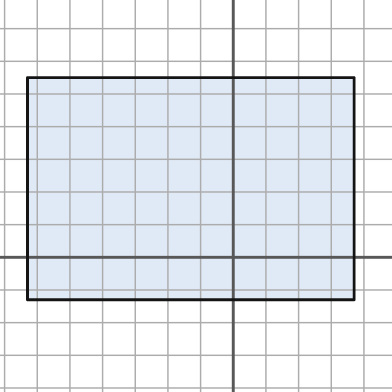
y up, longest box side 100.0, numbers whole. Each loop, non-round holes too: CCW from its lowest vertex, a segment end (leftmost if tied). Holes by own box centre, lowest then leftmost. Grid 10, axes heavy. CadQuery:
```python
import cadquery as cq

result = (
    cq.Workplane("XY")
    .moveTo(-63.0, -13.0)
    .lineTo(37.0, -13.0)
    .lineTo(37.0, 55.0)
    .lineTo(-63.0, 55.0)
    .close()
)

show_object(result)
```